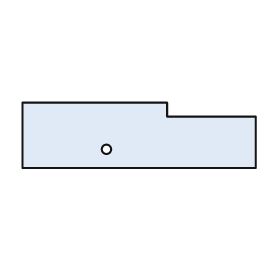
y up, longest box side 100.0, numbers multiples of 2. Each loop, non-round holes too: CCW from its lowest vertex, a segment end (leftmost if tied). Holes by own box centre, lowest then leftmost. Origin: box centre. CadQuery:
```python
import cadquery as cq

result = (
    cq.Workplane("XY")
    .moveTo(-50.0, -14.0)
    .lineTo(50.0, -14.0)
    .lineTo(50.0, 8.0)
    .lineTo(12.0, 8.0)
    .lineTo(12.0, 14.0)
    .lineTo(-50.0, 14.0)
    .close()
    .moveTo(-14.0, -6.0)
    .circle(2.0)
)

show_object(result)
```